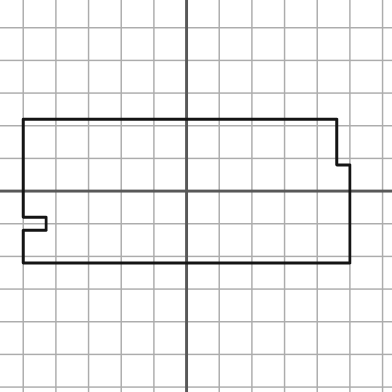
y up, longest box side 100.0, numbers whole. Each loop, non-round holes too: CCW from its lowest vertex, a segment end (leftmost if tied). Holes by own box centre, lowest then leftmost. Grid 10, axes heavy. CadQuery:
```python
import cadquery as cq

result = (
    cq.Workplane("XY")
    .moveTo(-50.0, -22.0)
    .lineTo(50.0, -22.0)
    .lineTo(50.0, 8.0)
    .lineTo(46.0, 8.0)
    .lineTo(46.0, 22.0)
    .lineTo(-50.0, 22.0)
    .lineTo(-50.0, -8.0)
    .lineTo(-43.0, -8.0)
    .lineTo(-43.0, -12.0)
    .lineTo(-50.0, -12.0)
    .close()
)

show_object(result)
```